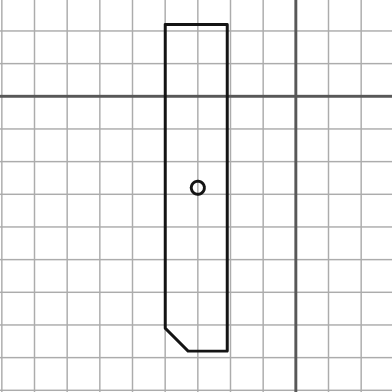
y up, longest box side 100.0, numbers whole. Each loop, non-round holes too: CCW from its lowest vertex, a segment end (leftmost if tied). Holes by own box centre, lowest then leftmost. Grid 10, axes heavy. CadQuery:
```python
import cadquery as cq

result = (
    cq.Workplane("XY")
    .moveTo(-33.0, -78.0)
    .lineTo(-21.0, -78.0)
    .lineTo(-21.0, 22.0)
    .lineTo(-40.0, 22.0)
    .lineTo(-40.0, -71.0)
    .close()
    .moveTo(-30.0, -28.0)
    .circle(2.0)
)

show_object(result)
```